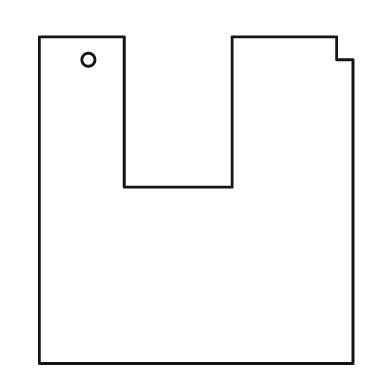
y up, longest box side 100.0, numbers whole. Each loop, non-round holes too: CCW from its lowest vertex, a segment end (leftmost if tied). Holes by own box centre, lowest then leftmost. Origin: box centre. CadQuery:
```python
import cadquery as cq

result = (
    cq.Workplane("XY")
    .moveTo(-48.0, -50.0)
    .lineTo(48.0, -50.0)
    .lineTo(48.0, 43.0)
    .lineTo(43.0, 43.0)
    .lineTo(43.0, 50.0)
    .lineTo(11.0, 50.0)
    .lineTo(11.0, 4.0)
    .lineTo(-22.0, 4.0)
    .lineTo(-22.0, 50.0)
    .lineTo(-48.0, 50.0)
    .close()
    .moveTo(-33.0, 43.0)
    .circle(2.0)
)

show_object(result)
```